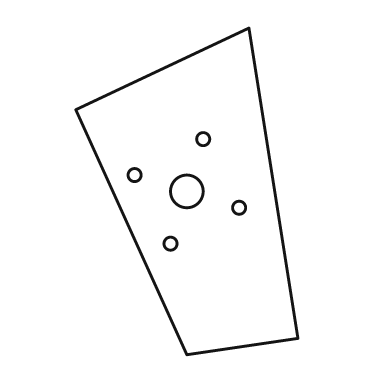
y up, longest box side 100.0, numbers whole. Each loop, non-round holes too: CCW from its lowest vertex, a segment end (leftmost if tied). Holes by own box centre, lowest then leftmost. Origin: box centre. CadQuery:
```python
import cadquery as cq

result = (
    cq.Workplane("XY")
    .moveTo(0.0, -50.0)
    .lineTo(34.0, -45.0)
    .lineTo(19.0, 50.0)
    .lineTo(-34.0, 25.0)
    .close()
    .moveTo(-5.0, -16.0)
    .circle(2.0)
    .moveTo(16.0, -5.0)
    .circle(2.0)
    .moveTo(0.0, 0.0)
    .circle(5.0)
    .moveTo(-16.0, 5.0)
    .circle(2.0)
    .moveTo(5.0, 16.0)
    .circle(2.0)
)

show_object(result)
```